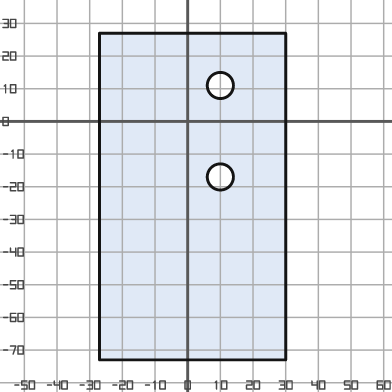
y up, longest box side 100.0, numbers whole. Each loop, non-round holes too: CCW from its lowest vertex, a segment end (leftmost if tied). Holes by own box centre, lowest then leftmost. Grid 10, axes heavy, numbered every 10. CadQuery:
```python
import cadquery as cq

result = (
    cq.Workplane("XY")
    .moveTo(-27.0, -73.0)
    .lineTo(30.0, -73.0)
    .lineTo(30.0, 27.0)
    .lineTo(-27.0, 27.0)
    .close()
    .moveTo(10.0, -17.0)
    .circle(4.0)
    .moveTo(10.0, 11.0)
    .circle(4.0)
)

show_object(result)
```